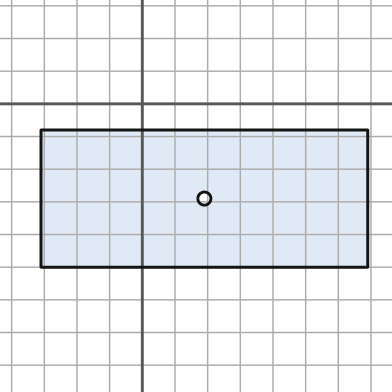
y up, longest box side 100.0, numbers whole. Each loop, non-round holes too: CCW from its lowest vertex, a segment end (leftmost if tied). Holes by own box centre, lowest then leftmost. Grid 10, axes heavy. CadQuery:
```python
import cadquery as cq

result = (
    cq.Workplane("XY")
    .moveTo(-31.0, -50.0)
    .lineTo(69.0, -50.0)
    .lineTo(69.0, -8.0)
    .lineTo(-31.0, -8.0)
    .close()
    .moveTo(19.0, -29.0)
    .circle(2.0)
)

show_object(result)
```